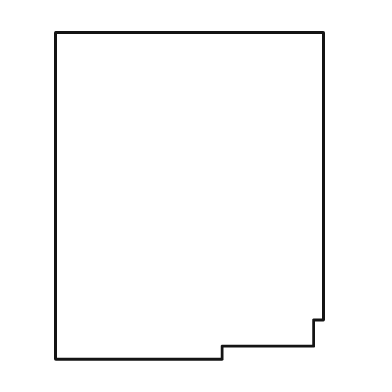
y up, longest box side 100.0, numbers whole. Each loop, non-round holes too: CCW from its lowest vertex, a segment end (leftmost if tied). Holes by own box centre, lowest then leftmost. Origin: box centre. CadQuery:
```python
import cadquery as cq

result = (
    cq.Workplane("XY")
    .moveTo(-41.0, -50.0)
    .lineTo(10.0, -50.0)
    .lineTo(10.0, -46.0)
    .lineTo(38.0, -46.0)
    .lineTo(38.0, -38.0)
    .lineTo(41.0, -38.0)
    .lineTo(41.0, 50.0)
    .lineTo(-41.0, 50.0)
    .close()
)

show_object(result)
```